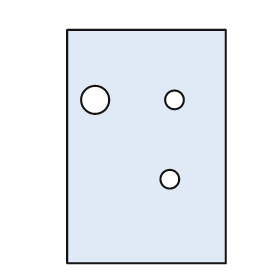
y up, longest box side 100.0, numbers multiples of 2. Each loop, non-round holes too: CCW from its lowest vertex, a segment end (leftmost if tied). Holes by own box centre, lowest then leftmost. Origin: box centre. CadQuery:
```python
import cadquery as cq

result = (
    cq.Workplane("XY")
    .moveTo(-34.0, -50.0)
    .lineTo(34.0, -50.0)
    .lineTo(34.0, 50.0)
    .lineTo(-34.0, 50.0)
    .close()
    .moveTo(10.0, -14.0)
    .circle(4.0)
    .moveTo(-22.0, 20.0)
    .circle(6.0)
    .moveTo(12.0, 20.0)
    .circle(4.0)
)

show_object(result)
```